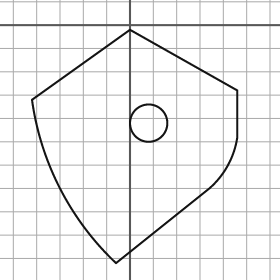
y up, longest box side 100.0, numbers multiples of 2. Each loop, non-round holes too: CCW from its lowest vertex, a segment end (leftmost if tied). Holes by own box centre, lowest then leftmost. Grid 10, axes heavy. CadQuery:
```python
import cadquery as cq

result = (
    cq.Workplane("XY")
    .moveTo(-6.0, -102.0)
    .lineTo(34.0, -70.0)
    .threePointArc((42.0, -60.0), (46.0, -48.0))
    .lineTo(46.0, -28.0)
    .lineTo(0.0, -2.0)
    .lineTo(-42.0, -32.0)
    .threePointArc((-30.0, -70.0), (-6.0, -102.0))
    .close()
    .moveTo(8.0, -42.0)
    .circle(8.0)
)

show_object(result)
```